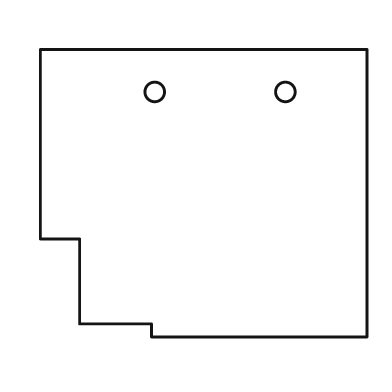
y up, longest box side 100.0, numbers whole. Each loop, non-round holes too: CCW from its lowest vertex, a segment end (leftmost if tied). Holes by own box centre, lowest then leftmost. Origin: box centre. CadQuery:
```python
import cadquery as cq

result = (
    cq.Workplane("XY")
    .moveTo(-16.0, -44.0)
    .lineTo(50.0, -44.0)
    .lineTo(50.0, 44.0)
    .lineTo(-50.0, 44.0)
    .lineTo(-50.0, -14.0)
    .lineTo(-38.0, -14.0)
    .lineTo(-38.0, -40.0)
    .lineTo(-16.0, -40.0)
    .close()
    .moveTo(-15.0, 31.0)
    .circle(3.0)
    .moveTo(25.0, 31.0)
    .circle(3.0)
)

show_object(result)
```